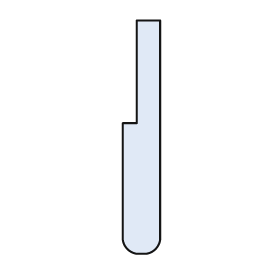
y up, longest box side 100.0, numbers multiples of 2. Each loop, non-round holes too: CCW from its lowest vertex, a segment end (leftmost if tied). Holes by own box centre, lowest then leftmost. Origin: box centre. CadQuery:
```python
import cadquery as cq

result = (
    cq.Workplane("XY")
    .moveTo(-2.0, -50.0)
    .lineTo(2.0, -50.0)
    .threePointArc((6.0, -48.0), (8.0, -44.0))
    .lineTo(8.0, 50.0)
    .lineTo(-2.0, 50.0)
    .lineTo(-2.0, 6.0)
    .lineTo(-8.0, 6.0)
    .lineTo(-8.0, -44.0)
    .threePointArc((-6.0, -48.0), (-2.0, -50.0))
    .close()
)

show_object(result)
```